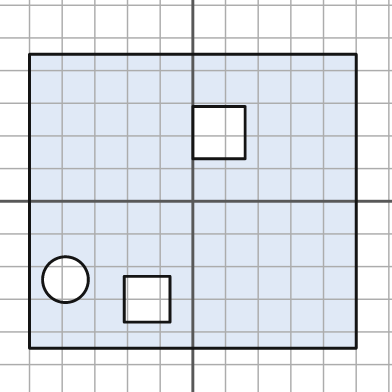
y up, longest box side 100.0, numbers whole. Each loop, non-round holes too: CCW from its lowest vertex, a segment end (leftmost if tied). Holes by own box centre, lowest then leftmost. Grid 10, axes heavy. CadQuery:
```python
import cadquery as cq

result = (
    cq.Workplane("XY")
    .moveTo(-50.0, -45.0)
    .lineTo(50.0, -45.0)
    .lineTo(50.0, 45.0)
    .lineTo(-50.0, 45.0)
    .close()
    .moveTo(-21.0, -37.0)
    .lineTo(-7.0, -37.0)
    .lineTo(-7.0, -23.0)
    .lineTo(-21.0, -23.0)
    .close()
    .moveTo(-39.0, -24.0)
    .circle(7.0)
    .moveTo(0.0, 13.0)
    .lineTo(16.0, 13.0)
    .lineTo(16.0, 29.0)
    .lineTo(0.0, 29.0)
    .close()
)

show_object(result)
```